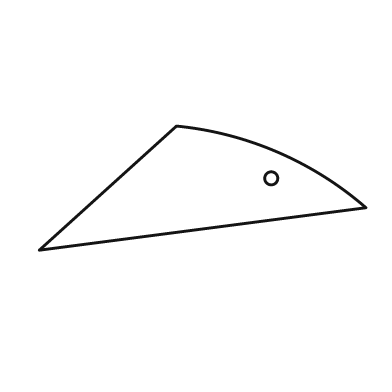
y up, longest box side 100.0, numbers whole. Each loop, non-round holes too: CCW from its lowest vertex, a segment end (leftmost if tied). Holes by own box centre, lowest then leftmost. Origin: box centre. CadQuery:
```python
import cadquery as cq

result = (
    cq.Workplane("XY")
    .moveTo(-50.0, -19.0)
    .lineTo(50.0, -6.0)
    .threePointArc((23.0, 11.0), (-8.0, 19.0))
    .close()
    .moveTo(21.0, 3.0)
    .circle(2.0)
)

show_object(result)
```